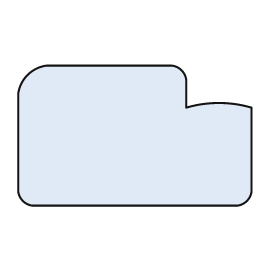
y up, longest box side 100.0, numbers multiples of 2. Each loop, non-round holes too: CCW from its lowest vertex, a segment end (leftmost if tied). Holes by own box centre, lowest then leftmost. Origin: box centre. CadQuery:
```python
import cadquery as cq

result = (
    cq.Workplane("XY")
    .moveTo(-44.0, -30.0)
    .lineTo(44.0, -30.0)
    .threePointArc((48.0, -28.0), (50.0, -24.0))
    .lineTo(50.0, 12.0)
    .threePointArc((36.0, 14.0), (22.0, 12.0))
    .lineTo(22.0, 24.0)
    .threePointArc((20.0, 28.0), (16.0, 30.0))
    .lineTo(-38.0, 30.0)
    .threePointArc((-46.0, 26.0), (-50.0, 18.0))
    .lineTo(-50.0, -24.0)
    .threePointArc((-48.0, -28.0), (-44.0, -30.0))
    .close()
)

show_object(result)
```